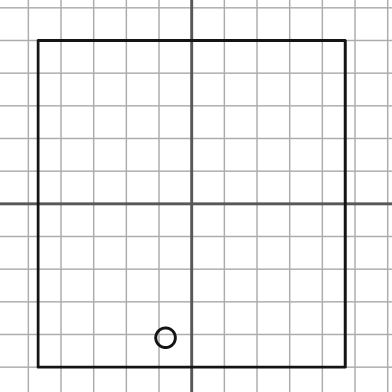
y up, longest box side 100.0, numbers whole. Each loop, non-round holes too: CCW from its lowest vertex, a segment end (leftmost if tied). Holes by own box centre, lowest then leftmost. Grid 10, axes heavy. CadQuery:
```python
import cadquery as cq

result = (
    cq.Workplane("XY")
    .moveTo(-47.0, -50.0)
    .lineTo(47.0, -50.0)
    .lineTo(47.0, 50.0)
    .lineTo(-47.0, 50.0)
    .close()
    .moveTo(-8.0, -41.0)
    .circle(3.0)
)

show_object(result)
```